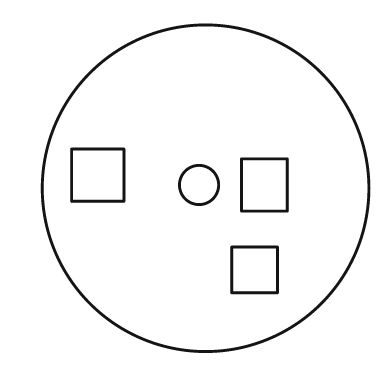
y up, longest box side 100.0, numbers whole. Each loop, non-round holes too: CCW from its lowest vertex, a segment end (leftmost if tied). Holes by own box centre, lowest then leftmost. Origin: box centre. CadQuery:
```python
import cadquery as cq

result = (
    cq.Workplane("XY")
    .moveTo(0.0, 0.0)
    .circle(50.0)
    .moveTo(8.0, -32.0)
    .lineTo(22.0, -32.0)
    .lineTo(22.0, -18.0)
    .lineTo(8.0, -18.0)
    .close()
    .moveTo(-2.0, 1.0)
    .circle(6.0)
    .moveTo(11.0, -7.0)
    .lineTo(25.0, -7.0)
    .lineTo(25.0, 9.0)
    .lineTo(11.0, 9.0)
    .close()
    .moveTo(-41.0, -4.0)
    .lineTo(-25.0, -4.0)
    .lineTo(-25.0, 12.0)
    .lineTo(-41.0, 12.0)
    .close()
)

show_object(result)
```